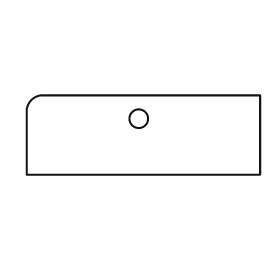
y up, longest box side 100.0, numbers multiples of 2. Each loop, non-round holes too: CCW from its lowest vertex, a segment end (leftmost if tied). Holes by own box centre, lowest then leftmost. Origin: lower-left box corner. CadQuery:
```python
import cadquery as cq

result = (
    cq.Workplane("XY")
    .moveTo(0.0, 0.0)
    .lineTo(100.0, 0.0)
    .lineTo(100.0, 34.0)
    .lineTo(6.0, 34.0)
    .threePointArc((2.0, 32.0), (0.0, 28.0))
    .close()
    .moveTo(48.0, 24.0)
    .circle(4.0)
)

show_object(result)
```